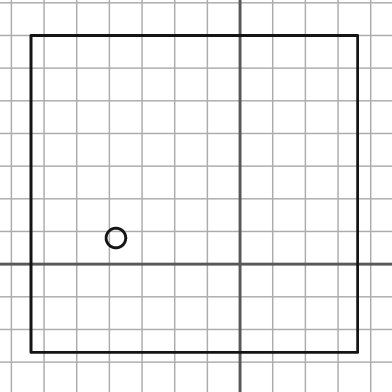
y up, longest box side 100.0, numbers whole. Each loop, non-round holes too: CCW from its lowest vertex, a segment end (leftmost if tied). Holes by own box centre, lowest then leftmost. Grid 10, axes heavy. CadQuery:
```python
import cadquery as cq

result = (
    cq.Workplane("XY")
    .moveTo(-64.0, -27.0)
    .lineTo(36.0, -27.0)
    .lineTo(36.0, 70.0)
    .lineTo(-64.0, 70.0)
    .close()
    .moveTo(-38.0, 8.0)
    .circle(3.0)
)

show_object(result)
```